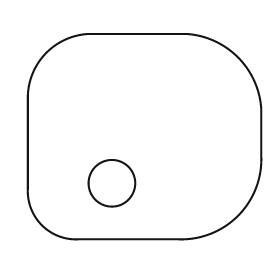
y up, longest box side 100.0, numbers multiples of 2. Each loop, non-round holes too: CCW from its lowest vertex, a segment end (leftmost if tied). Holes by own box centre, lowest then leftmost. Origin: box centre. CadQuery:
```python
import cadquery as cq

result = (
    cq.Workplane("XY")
    .moveTo(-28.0, -44.0)
    .lineTo(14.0, -44.0)
    .threePointArc((40.0, -34.0), (50.0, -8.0))
    .lineTo(50.0, 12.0)
    .threePointArc((40.0, 34.0), (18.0, 44.0))
    .lineTo(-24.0, 44.0)
    .threePointArc((-42.0, 36.0), (-50.0, 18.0))
    .lineTo(-50.0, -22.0)
    .threePointArc((-44.0, -38.0), (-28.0, -44.0))
    .close()
    .moveTo(-14.0, -20.0)
    .circle(10.0)
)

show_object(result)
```